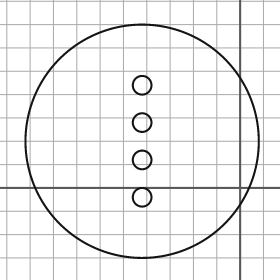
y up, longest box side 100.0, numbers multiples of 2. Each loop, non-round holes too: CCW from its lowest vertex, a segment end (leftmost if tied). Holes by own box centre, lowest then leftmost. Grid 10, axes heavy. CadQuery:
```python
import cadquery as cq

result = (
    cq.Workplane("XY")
    .moveTo(-42.0, 20.0)
    .circle(50.0)
    .moveTo(-42.0, -4.0)
    .circle(4.0)
    .moveTo(-42.0, 12.0)
    .circle(4.0)
    .moveTo(-42.0, 28.0)
    .circle(4.0)
    .moveTo(-42.0, 44.0)
    .circle(4.0)
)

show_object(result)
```